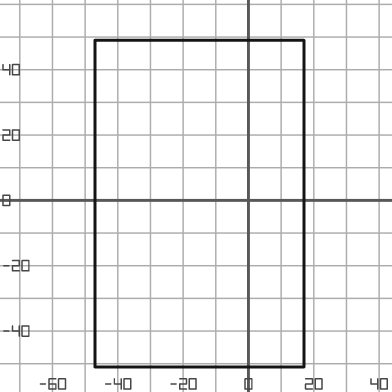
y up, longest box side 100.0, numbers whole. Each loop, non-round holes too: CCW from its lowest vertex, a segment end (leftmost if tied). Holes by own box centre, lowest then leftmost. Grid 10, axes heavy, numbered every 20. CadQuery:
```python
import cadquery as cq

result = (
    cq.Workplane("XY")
    .moveTo(-47.0, -51.0)
    .lineTo(17.0, -51.0)
    .lineTo(17.0, 49.0)
    .lineTo(-47.0, 49.0)
    .close()
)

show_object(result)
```